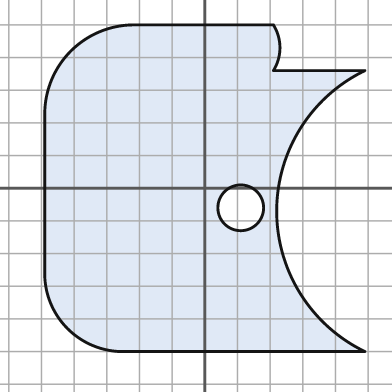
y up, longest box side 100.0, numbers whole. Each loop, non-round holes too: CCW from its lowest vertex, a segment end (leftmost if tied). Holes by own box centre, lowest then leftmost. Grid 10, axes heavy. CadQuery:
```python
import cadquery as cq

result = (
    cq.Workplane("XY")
    .moveTo(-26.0, -50.0)
    .lineTo(49.0, -50.0)
    .threePointArc((22.0, -7.0), (49.0, 36.0))
    .lineTo(21.0, 36.0)
    .threePointArc((23.0, 43.0), (21.0, 50.0))
    .lineTo(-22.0, 50.0)
    .threePointArc((-41.0, 42.0), (-49.0, 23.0))
    .lineTo(-49.0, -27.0)
    .threePointArc((-42.0, -43.0), (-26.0, -50.0))
    .close()
    .moveTo(11.0, -6.0)
    .circle(7.0)
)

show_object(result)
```